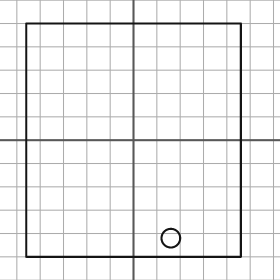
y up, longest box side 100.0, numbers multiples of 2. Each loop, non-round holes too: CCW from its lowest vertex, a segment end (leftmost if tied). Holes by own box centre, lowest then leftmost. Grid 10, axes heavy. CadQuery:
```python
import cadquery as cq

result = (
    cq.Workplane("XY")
    .moveTo(-46.0, -50.0)
    .lineTo(46.0, -50.0)
    .lineTo(46.0, 50.0)
    .lineTo(-46.0, 50.0)
    .close()
    .moveTo(16.0, -42.0)
    .circle(4.0)
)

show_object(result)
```